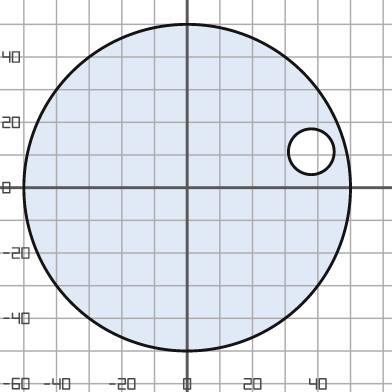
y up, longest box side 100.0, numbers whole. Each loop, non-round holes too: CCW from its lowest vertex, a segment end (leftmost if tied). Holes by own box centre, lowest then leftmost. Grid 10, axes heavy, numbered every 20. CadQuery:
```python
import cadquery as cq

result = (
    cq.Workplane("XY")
    .moveTo(0.0, 0.0)
    .circle(50.0)
    .moveTo(38.0, 11.0)
    .circle(7.0)
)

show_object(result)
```